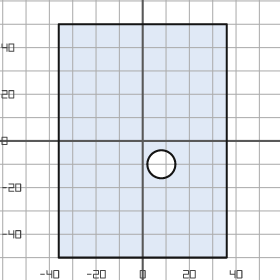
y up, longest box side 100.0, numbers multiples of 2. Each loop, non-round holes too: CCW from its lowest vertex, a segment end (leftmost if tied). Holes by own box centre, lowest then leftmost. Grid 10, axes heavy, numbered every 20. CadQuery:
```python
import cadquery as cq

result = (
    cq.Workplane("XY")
    .moveTo(-36.0, -50.0)
    .lineTo(36.0, -50.0)
    .lineTo(36.0, 50.0)
    .lineTo(-36.0, 50.0)
    .close()
    .moveTo(8.0, -10.0)
    .circle(6.0)
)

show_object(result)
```